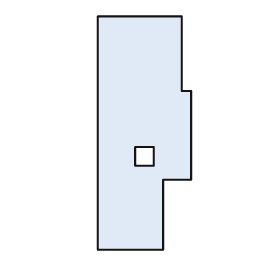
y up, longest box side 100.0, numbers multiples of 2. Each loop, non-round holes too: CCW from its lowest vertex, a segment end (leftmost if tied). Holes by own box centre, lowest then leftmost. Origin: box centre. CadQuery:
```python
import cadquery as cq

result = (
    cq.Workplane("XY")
    .moveTo(-20.0, -50.0)
    .lineTo(8.0, -50.0)
    .lineTo(8.0, -20.0)
    .lineTo(20.0, -20.0)
    .lineTo(20.0, 18.0)
    .lineTo(16.0, 18.0)
    .lineTo(16.0, 50.0)
    .lineTo(-20.0, 50.0)
    .close()
    .moveTo(-4.0, -14.0)
    .lineTo(4.0, -14.0)
    .lineTo(4.0, -6.0)
    .lineTo(-4.0, -6.0)
    .close()
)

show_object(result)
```